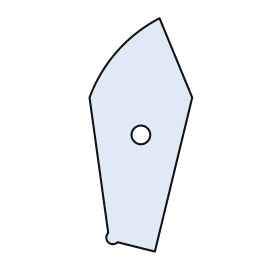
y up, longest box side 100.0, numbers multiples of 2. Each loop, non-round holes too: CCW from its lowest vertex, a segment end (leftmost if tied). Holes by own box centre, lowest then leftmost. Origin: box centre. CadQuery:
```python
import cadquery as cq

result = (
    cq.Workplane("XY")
    .moveTo(6.0, -50.0)
    .lineTo(22.0, 16.0)
    .lineTo(8.0, 50.0)
    .threePointArc((-10.0, 36.0), (-22.0, 16.0))
    .lineTo(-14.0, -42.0)
    .threePointArc((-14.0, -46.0), (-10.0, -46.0))
    .close()
    .moveTo(0.0, 0.0)
    .circle(4.0)
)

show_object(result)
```